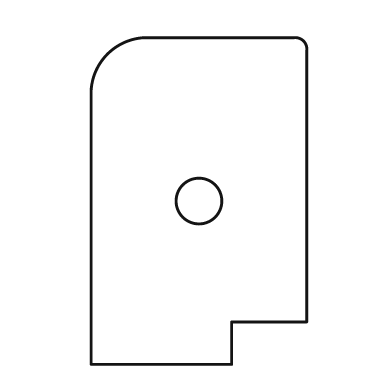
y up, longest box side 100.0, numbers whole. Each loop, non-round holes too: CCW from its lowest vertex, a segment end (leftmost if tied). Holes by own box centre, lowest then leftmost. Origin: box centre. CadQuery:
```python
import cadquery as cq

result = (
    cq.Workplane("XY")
    .moveTo(-33.0, -50.0)
    .lineTo(10.0, -50.0)
    .lineTo(10.0, -37.0)
    .lineTo(33.0, -37.0)
    .lineTo(33.0, 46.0)
    .threePointArc((32.0, 49.0), (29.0, 50.0))
    .lineTo(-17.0, 50.0)
    .threePointArc((-28.0, 45.0), (-33.0, 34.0))
    .close()
    .moveTo(0.0, 0.0)
    .circle(7.0)
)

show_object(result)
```